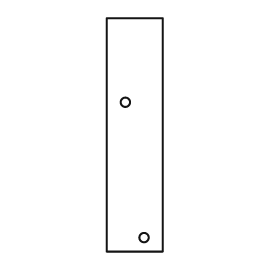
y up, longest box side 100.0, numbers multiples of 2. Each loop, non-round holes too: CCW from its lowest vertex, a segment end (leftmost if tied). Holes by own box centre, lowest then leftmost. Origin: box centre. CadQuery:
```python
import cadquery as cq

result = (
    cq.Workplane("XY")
    .moveTo(-12.0, -50.0)
    .lineTo(12.0, -50.0)
    .lineTo(12.0, 50.0)
    .lineTo(-12.0, 50.0)
    .close()
    .moveTo(4.0, -44.0)
    .circle(2.0)
    .moveTo(-4.0, 14.0)
    .circle(2.0)
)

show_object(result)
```